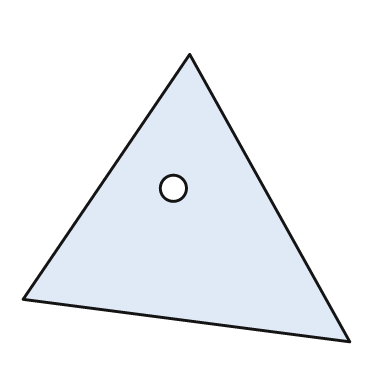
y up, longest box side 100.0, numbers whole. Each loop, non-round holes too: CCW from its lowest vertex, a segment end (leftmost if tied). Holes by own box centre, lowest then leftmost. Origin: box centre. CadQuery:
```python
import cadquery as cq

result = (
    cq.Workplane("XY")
    .moveTo(50.0, -44.0)
    .lineTo(1.0, 44.0)
    .lineTo(-50.0, -31.0)
    .close()
    .moveTo(-4.0, 3.0)
    .circle(4.0)
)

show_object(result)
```